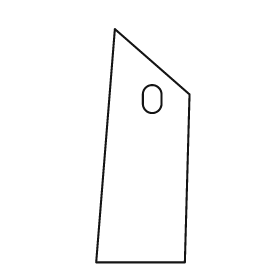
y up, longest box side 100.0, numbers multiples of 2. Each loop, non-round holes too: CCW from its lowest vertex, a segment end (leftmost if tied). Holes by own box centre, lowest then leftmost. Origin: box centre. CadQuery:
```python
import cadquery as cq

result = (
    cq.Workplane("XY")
    .moveTo(-20.0, -50.0)
    .lineTo(18.0, -50.0)
    .lineTo(20.0, 22.0)
    .lineTo(-12.0, 50.0)
    .close()
    .moveTo(0.0, 18.0)
    .threePointArc((4.0, 14.0), (8.0, 18.0))
    .lineTo(8.0, 22.0)
    .threePointArc((4.0, 26.0), (0.0, 22.0))
    .close()
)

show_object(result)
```